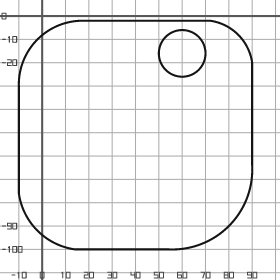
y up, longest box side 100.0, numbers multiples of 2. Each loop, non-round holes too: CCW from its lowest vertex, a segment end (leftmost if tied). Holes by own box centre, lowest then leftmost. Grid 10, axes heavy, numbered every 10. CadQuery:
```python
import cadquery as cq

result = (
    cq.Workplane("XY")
    .moveTo(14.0, -100.0)
    .lineTo(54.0, -100.0)
    .threePointArc((80.0, -90.0), (90.0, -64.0))
    .lineTo(90.0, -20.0)
    .threePointArc((84.0, -8.0), (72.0, -2.0))
    .lineTo(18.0, -2.0)
    .threePointArc((-2.0, -10.0), (-10.0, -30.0))
    .lineTo(-10.0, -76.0)
    .threePointArc((-2.0, -92.0), (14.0, -100.0))
    .close()
    .moveTo(60.0, -16.0)
    .circle(10.0)
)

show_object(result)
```